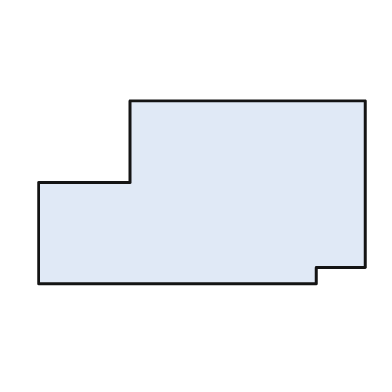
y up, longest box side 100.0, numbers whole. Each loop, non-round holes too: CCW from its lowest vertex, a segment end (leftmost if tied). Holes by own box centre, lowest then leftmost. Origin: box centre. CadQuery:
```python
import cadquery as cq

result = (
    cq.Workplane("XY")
    .moveTo(-50.0, -28.0)
    .lineTo(35.0, -28.0)
    .lineTo(35.0, -23.0)
    .lineTo(50.0, -23.0)
    .lineTo(50.0, 28.0)
    .lineTo(-22.0, 28.0)
    .lineTo(-22.0, 3.0)
    .lineTo(-50.0, 3.0)
    .close()
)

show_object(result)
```